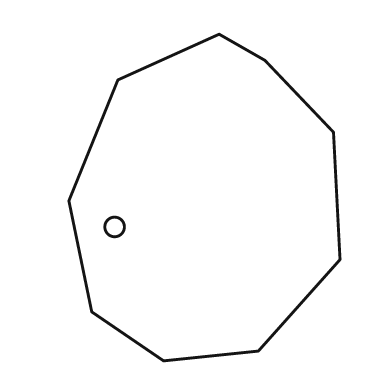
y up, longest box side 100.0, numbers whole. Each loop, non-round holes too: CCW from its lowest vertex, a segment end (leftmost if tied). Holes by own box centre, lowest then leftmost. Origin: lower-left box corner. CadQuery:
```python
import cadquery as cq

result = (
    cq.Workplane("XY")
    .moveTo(29.0, 0.0)
    .lineTo(58.0, 3.0)
    .lineTo(83.0, 31.0)
    .lineTo(81.0, 70.0)
    .lineTo(60.0, 92.0)
    .lineTo(46.0, 100.0)
    .lineTo(15.0, 86.0)
    .lineTo(0.0, 49.0)
    .lineTo(7.0, 15.0)
    .close()
    .moveTo(14.0, 41.0)
    .circle(3.0)
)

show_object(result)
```